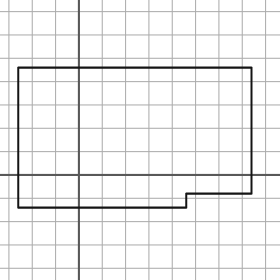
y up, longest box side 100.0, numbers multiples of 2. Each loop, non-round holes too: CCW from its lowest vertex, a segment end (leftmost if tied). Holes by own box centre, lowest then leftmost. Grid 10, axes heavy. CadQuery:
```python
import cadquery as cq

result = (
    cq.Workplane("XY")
    .moveTo(-26.0, -14.0)
    .lineTo(46.0, -14.0)
    .lineTo(46.0, -8.0)
    .lineTo(74.0, -8.0)
    .lineTo(74.0, 46.0)
    .lineTo(-26.0, 46.0)
    .close()
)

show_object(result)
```